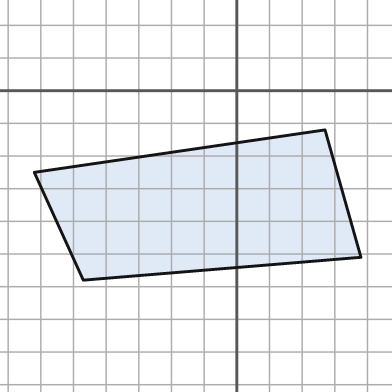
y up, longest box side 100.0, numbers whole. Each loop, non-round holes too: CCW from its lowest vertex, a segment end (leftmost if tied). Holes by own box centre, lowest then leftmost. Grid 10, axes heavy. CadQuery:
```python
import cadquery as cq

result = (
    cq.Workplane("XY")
    .moveTo(-47.0, -58.0)
    .lineTo(38.0, -51.0)
    .lineTo(27.0, -12.0)
    .lineTo(-62.0, -25.0)
    .close()
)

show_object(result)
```